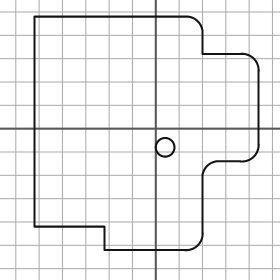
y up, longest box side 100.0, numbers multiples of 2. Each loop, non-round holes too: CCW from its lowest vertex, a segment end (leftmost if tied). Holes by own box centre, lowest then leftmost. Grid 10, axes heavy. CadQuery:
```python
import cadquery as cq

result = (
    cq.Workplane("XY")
    .moveTo(-22.0, -52.0)
    .lineTo(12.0, -52.0)
    .threePointArc((18.0, -50.0), (20.0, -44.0))
    .lineTo(20.0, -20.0)
    .threePointArc((22.0, -16.0), (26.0, -14.0))
    .lineTo(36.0, -14.0)
    .threePointArc((42.0, -12.0), (44.0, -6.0))
    .lineTo(44.0, 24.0)
    .threePointArc((42.0, 30.0), (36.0, 32.0))
    .lineTo(20.0, 32.0)
    .lineTo(20.0, 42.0)
    .threePointArc((18.0, 46.0), (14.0, 48.0))
    .lineTo(-52.0, 48.0)
    .lineTo(-52.0, -42.0)
    .lineTo(-22.0, -42.0)
    .close()
    .moveTo(4.0, -8.0)
    .circle(4.0)
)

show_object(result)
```